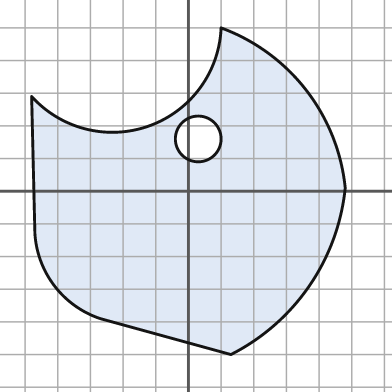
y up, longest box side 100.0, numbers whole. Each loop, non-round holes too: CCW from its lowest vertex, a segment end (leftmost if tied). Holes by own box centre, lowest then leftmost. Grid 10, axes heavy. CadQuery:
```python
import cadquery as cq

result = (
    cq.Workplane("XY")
    .moveTo(13.0, -50.0)
    .threePointArc((37.0, -29.0), (48.0, 1.0))
    .threePointArc((36.0, 31.0), (10.0, 50.0))
    .threePointArc((-12.0, 20.0), (-48.0, 29.0))
    .lineTo(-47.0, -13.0)
    .threePointArc((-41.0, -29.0), (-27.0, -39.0))
    .close()
    .moveTo(3.0, 16.0)
    .circle(7.0)
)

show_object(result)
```